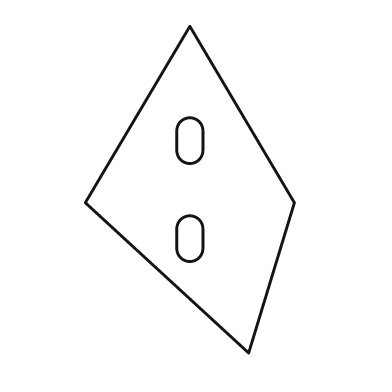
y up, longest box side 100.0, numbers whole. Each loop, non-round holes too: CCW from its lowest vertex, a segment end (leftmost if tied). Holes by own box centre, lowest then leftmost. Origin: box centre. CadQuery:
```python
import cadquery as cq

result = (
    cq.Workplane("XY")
    .moveTo(18.0, -50.0)
    .lineTo(32.0, -4.0)
    .lineTo(0.0, 50.0)
    .lineTo(-32.0, -4.0)
    .close()
    .moveTo(-4.0, -18.0)
    .threePointArc((0.0, -22.0), (4.0, -18.0))
    .lineTo(4.0, -12.0)
    .threePointArc((0.0, -8.0), (-4.0, -12.0))
    .close()
    .moveTo(-4.0, 12.0)
    .threePointArc((0.0, 8.0), (4.0, 12.0))
    .lineTo(4.0, 18.0)
    .threePointArc((0.0, 22.0), (-4.0, 18.0))
    .close()
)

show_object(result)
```